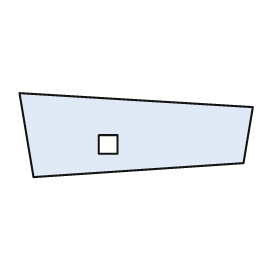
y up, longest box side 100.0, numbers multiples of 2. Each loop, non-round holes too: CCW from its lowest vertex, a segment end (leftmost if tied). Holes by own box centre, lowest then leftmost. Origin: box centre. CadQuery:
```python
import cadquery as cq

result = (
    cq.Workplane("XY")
    .moveTo(-44.0, -18.0)
    .lineTo(46.0, -12.0)
    .lineTo(50.0, 12.0)
    .lineTo(-50.0, 18.0)
    .close()
    .moveTo(-16.0, -8.0)
    .lineTo(-8.0, -8.0)
    .lineTo(-8.0, 0.0)
    .lineTo(-16.0, 0.0)
    .close()
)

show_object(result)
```